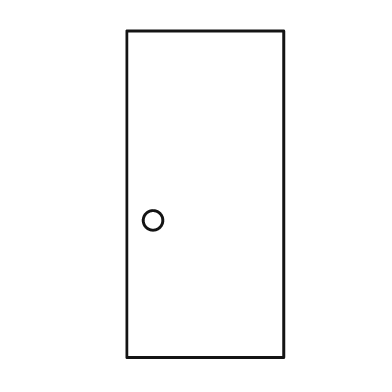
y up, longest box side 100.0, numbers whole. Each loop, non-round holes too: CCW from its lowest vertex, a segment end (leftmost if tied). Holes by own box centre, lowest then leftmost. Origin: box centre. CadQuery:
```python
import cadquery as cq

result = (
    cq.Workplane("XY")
    .moveTo(-24.0, -50.0)
    .lineTo(24.0, -50.0)
    .lineTo(24.0, 50.0)
    .lineTo(-24.0, 50.0)
    .close()
    .moveTo(-16.0, -8.0)
    .circle(3.0)
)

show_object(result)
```